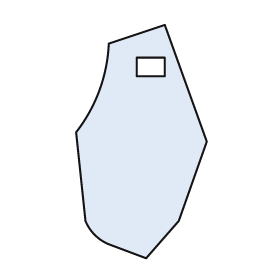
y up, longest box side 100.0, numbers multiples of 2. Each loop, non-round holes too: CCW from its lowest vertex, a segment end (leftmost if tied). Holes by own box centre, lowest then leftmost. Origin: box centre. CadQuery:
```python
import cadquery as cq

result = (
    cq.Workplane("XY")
    .moveTo(2.0, -50.0)
    .lineTo(16.0, -34.0)
    .lineTo(28.0, 0.0)
    .lineTo(10.0, 50.0)
    .lineTo(-14.0, 42.0)
    .threePointArc((-18.0, 22.0), (-28.0, 4.0))
    .lineTo(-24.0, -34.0)
    .threePointArc((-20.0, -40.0), (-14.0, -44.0))
    .close()
    .moveTo(-2.0, 28.0)
    .lineTo(10.0, 28.0)
    .lineTo(10.0, 36.0)
    .lineTo(-2.0, 36.0)
    .close()
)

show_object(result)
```